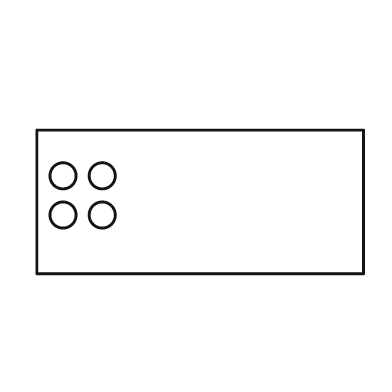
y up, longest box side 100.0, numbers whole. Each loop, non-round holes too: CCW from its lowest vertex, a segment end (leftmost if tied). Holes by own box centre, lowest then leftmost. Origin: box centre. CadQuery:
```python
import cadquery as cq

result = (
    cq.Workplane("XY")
    .moveTo(-50.0, -22.0)
    .lineTo(50.0, -22.0)
    .lineTo(50.0, 22.0)
    .lineTo(-50.0, 22.0)
    .close()
    .moveTo(-42.0, -4.0)
    .circle(4.0)
    .moveTo(-30.0, -4.0)
    .circle(4.0)
    .moveTo(-42.0, 8.0)
    .circle(4.0)
    .moveTo(-30.0, 8.0)
    .circle(4.0)
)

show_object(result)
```